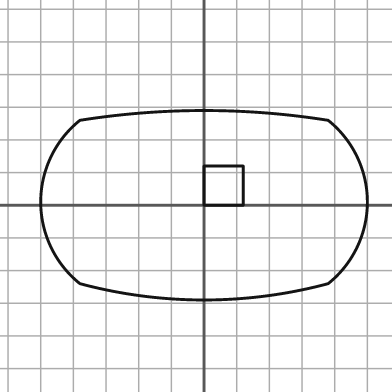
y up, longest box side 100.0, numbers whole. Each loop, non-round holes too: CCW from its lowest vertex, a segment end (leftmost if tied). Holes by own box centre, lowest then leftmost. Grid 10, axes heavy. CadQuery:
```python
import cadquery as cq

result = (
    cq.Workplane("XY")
    .moveTo(-38.0, -24.0)
    .threePointArc((0.0, -29.0), (38.0, -24.0))
    .threePointArc((50.0, 1.0), (38.0, 26.0))
    .threePointArc((0.0, 29.0), (-38.0, 26.0))
    .threePointArc((-50.0, 1.0), (-38.0, -24.0))
    .close()
    .moveTo(0.0, 0.0)
    .lineTo(12.0, 0.0)
    .lineTo(12.0, 12.0)
    .lineTo(0.0, 12.0)
    .close()
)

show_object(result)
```